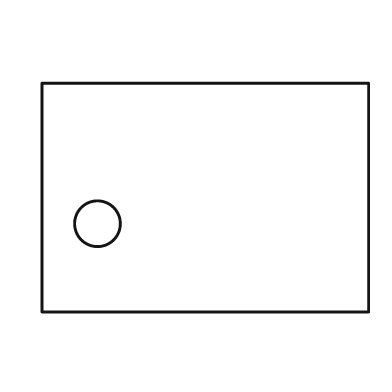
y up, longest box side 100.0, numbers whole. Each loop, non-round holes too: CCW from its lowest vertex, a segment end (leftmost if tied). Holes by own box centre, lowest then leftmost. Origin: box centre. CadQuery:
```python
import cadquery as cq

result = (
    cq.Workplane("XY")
    .moveTo(-50.0, -35.0)
    .lineTo(50.0, -35.0)
    .lineTo(50.0, 35.0)
    .lineTo(-50.0, 35.0)
    .close()
    .moveTo(-33.0, -8.0)
    .circle(7.0)
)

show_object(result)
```